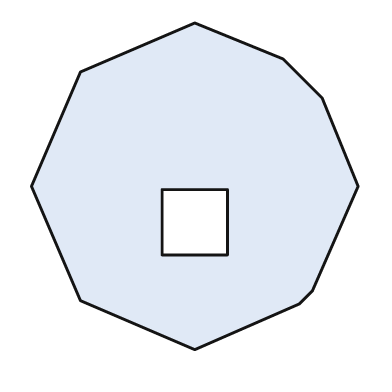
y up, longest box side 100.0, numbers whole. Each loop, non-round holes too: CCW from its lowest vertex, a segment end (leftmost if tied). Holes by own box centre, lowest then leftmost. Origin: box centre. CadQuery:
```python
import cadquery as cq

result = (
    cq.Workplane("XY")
    .moveTo(0.0, -50.0)
    .lineTo(32.0, -36.0)
    .lineTo(36.0, -32.0)
    .lineTo(50.0, 0.0)
    .lineTo(39.0, 27.0)
    .lineTo(27.0, 39.0)
    .lineTo(0.0, 50.0)
    .lineTo(-35.0, 35.0)
    .lineTo(-50.0, 0.0)
    .lineTo(-35.0, -35.0)
    .close()
    .moveTo(-10.0, -21.0)
    .lineTo(10.0, -21.0)
    .lineTo(10.0, -1.0)
    .lineTo(-10.0, -1.0)
    .close()
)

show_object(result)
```